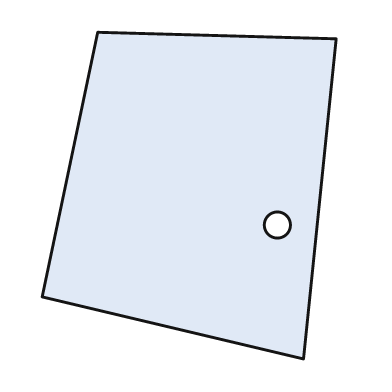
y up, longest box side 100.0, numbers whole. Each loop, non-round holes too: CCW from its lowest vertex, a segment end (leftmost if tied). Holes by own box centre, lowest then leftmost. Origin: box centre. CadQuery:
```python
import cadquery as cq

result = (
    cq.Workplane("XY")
    .moveTo(35.0, -50.0)
    .lineTo(45.0, 48.0)
    .lineTo(-28.0, 50.0)
    .lineTo(-45.0, -31.0)
    .close()
    .moveTo(27.0, -9.0)
    .circle(4.0)
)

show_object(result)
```